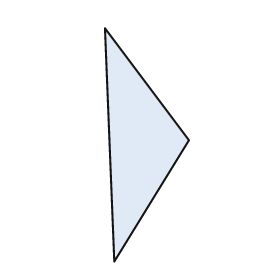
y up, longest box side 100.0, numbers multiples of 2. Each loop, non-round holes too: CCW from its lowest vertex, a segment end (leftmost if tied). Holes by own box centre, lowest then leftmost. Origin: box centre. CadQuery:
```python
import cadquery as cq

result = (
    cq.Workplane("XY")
    .moveTo(-14.0, -50.0)
    .lineTo(18.0, 2.0)
    .lineTo(-18.0, 50.0)
    .close()
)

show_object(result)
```